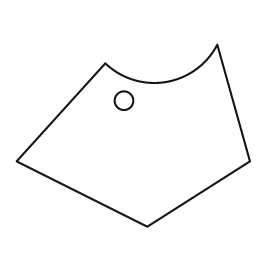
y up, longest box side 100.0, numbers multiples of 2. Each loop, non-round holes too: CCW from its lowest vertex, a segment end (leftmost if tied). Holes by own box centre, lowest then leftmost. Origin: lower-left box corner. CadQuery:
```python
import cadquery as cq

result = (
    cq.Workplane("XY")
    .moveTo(56.0, 0.0)
    .lineTo(100.0, 28.0)
    .lineTo(86.0, 78.0)
    .threePointArc((64.0, 62.0), (38.0, 70.0))
    .lineTo(0.0, 28.0)
    .close()
    .moveTo(46.0, 54.0)
    .circle(4.0)
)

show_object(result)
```